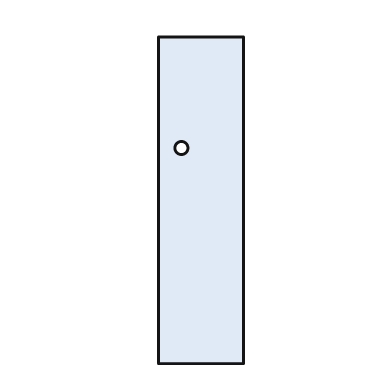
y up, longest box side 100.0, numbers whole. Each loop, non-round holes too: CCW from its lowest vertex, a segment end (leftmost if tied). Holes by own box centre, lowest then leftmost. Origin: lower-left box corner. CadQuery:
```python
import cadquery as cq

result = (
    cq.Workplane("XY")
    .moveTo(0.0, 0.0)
    .lineTo(26.0, 0.0)
    .lineTo(26.0, 100.0)
    .lineTo(0.0, 100.0)
    .close()
    .moveTo(7.0, 66.0)
    .circle(2.0)
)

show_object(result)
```